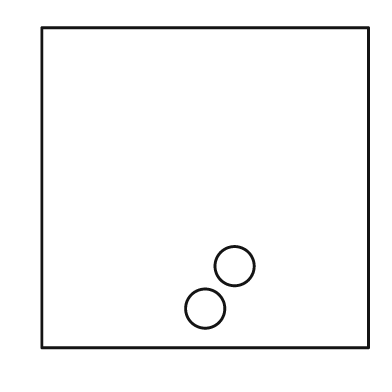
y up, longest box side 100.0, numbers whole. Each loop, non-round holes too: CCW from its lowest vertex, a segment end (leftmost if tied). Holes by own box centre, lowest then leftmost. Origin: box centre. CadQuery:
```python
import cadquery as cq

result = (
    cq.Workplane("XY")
    .moveTo(-50.0, -49.0)
    .lineTo(50.0, -49.0)
    .lineTo(50.0, 49.0)
    .lineTo(-50.0, 49.0)
    .close()
    .moveTo(0.0, -37.0)
    .circle(6.0)
    .moveTo(9.0, -24.0)
    .circle(6.0)
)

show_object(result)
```